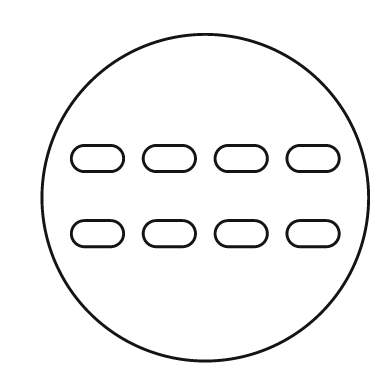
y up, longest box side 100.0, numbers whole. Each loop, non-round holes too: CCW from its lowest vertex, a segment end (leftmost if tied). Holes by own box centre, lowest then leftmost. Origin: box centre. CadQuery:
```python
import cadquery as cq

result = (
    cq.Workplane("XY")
    .moveTo(0.0, 0.0)
    .circle(50.0)
    .moveTo(-37.0, -15.0)
    .lineTo(-29.0, -15.0)
    .threePointArc((-25.0, -11.0), (-29.0, -7.0))
    .lineTo(-37.0, -7.0)
    .threePointArc((-41.0, -11.0), (-37.0, -15.0))
    .close()
    .moveTo(-15.0, -15.0)
    .lineTo(-7.0, -15.0)
    .threePointArc((-3.0, -11.0), (-7.0, -7.0))
    .lineTo(-15.0, -7.0)
    .threePointArc((-19.0, -11.0), (-15.0, -15.0))
    .close()
    .moveTo(7.0, -15.0)
    .lineTo(15.0, -15.0)
    .threePointArc((19.0, -11.0), (15.0, -7.0))
    .lineTo(7.0, -7.0)
    .threePointArc((3.0, -11.0), (7.0, -15.0))
    .close()
    .moveTo(29.0, -15.0)
    .lineTo(37.0, -15.0)
    .threePointArc((41.0, -11.0), (37.0, -7.0))
    .lineTo(29.0, -7.0)
    .threePointArc((25.0, -11.0), (29.0, -15.0))
    .close()
    .moveTo(-37.0, 8.0)
    .lineTo(-29.0, 8.0)
    .threePointArc((-25.0, 12.0), (-29.0, 16.0))
    .lineTo(-37.0, 16.0)
    .threePointArc((-41.0, 12.0), (-37.0, 8.0))
    .close()
    .moveTo(-15.0, 8.0)
    .lineTo(-7.0, 8.0)
    .threePointArc((-3.0, 12.0), (-7.0, 16.0))
    .lineTo(-15.0, 16.0)
    .threePointArc((-19.0, 12.0), (-15.0, 8.0))
    .close()
    .moveTo(7.0, 8.0)
    .lineTo(15.0, 8.0)
    .threePointArc((19.0, 12.0), (15.0, 16.0))
    .lineTo(7.0, 16.0)
    .threePointArc((3.0, 12.0), (7.0, 8.0))
    .close()
    .moveTo(29.0, 8.0)
    .lineTo(37.0, 8.0)
    .threePointArc((41.0, 12.0), (37.0, 16.0))
    .lineTo(29.0, 16.0)
    .threePointArc((25.0, 12.0), (29.0, 8.0))
    .close()
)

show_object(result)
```